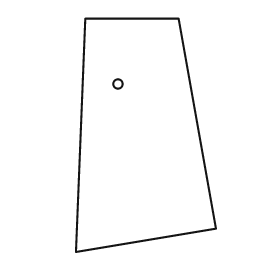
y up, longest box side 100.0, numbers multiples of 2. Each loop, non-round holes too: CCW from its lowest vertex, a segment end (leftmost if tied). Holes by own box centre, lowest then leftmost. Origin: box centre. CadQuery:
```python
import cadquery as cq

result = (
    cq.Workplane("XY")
    .moveTo(-30.0, -50.0)
    .lineTo(30.0, -40.0)
    .lineTo(14.0, 50.0)
    .lineTo(-26.0, 50.0)
    .close()
    .moveTo(-12.0, 22.0)
    .circle(2.0)
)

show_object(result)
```